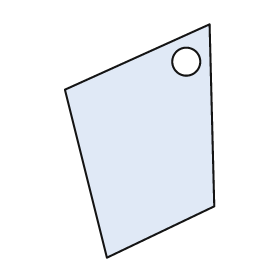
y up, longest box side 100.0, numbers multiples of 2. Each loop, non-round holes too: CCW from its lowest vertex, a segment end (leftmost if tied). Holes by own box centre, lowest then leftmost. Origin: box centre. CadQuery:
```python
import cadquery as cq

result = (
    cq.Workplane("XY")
    .moveTo(-14.0, -50.0)
    .lineTo(32.0, -28.0)
    .lineTo(30.0, 50.0)
    .lineTo(-32.0, 22.0)
    .close()
    .moveTo(20.0, 34.0)
    .circle(6.0)
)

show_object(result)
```